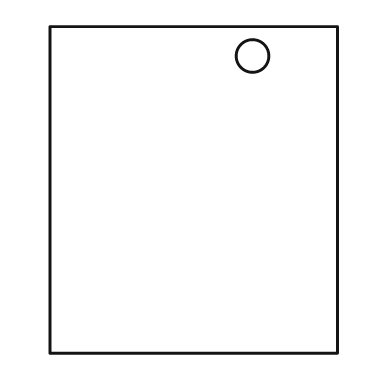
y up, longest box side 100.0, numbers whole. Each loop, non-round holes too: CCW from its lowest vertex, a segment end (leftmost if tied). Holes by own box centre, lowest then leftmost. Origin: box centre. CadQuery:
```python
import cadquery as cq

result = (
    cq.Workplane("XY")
    .moveTo(-44.0, -50.0)
    .lineTo(44.0, -50.0)
    .lineTo(44.0, 50.0)
    .lineTo(-44.0, 50.0)
    .close()
    .moveTo(18.0, 41.0)
    .circle(5.0)
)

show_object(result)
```